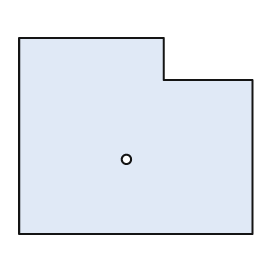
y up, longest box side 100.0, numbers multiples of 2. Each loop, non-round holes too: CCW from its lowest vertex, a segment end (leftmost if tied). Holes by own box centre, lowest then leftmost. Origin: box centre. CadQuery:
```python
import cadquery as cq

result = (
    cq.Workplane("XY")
    .moveTo(-50.0, -42.0)
    .lineTo(50.0, -42.0)
    .lineTo(50.0, 24.0)
    .lineTo(12.0, 24.0)
    .lineTo(12.0, 42.0)
    .lineTo(-50.0, 42.0)
    .close()
    .moveTo(-4.0, -10.0)
    .circle(2.0)
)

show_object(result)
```